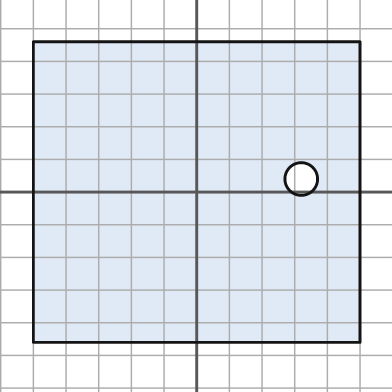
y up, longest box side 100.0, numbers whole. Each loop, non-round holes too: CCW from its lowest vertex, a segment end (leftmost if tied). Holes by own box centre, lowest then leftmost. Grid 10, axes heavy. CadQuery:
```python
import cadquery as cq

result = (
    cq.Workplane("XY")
    .moveTo(-50.0, -46.0)
    .lineTo(50.0, -46.0)
    .lineTo(50.0, 46.0)
    .lineTo(-50.0, 46.0)
    .close()
    .moveTo(32.0, 4.0)
    .circle(5.0)
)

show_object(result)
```